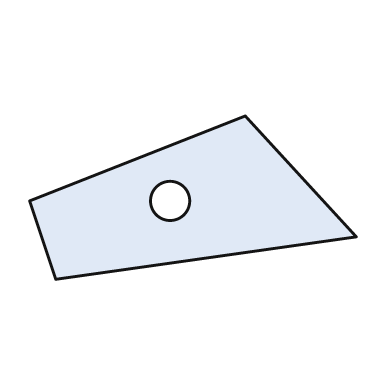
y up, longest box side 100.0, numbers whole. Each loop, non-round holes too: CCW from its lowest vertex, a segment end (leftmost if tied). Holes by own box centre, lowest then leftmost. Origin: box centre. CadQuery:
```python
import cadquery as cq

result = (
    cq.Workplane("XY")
    .moveTo(-42.0, -25.0)
    .lineTo(50.0, -12.0)
    .lineTo(16.0, 25.0)
    .lineTo(-50.0, -1.0)
    .close()
    .moveTo(-7.0, -1.0)
    .circle(6.0)
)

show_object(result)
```